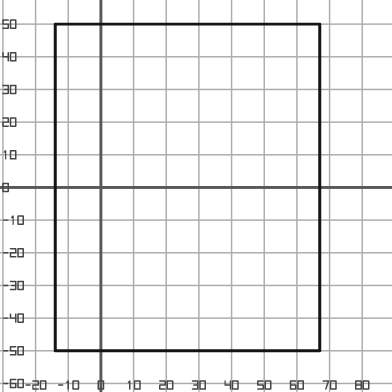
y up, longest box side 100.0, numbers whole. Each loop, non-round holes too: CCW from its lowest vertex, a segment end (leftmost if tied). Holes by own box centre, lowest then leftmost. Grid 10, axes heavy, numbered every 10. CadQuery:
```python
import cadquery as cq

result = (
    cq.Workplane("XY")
    .moveTo(-14.0, -50.0)
    .lineTo(67.0, -50.0)
    .lineTo(67.0, 50.0)
    .lineTo(-14.0, 50.0)
    .close()
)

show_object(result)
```